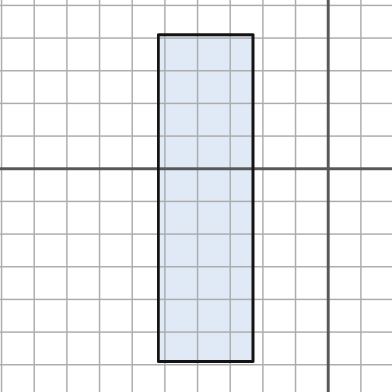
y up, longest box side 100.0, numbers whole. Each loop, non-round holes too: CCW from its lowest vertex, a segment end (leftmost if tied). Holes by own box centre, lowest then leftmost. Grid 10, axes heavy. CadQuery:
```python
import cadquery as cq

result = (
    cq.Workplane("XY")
    .moveTo(-52.0, -59.0)
    .lineTo(-23.0, -59.0)
    .lineTo(-23.0, 41.0)
    .lineTo(-52.0, 41.0)
    .close()
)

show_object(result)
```